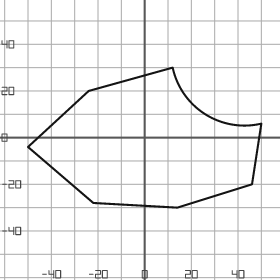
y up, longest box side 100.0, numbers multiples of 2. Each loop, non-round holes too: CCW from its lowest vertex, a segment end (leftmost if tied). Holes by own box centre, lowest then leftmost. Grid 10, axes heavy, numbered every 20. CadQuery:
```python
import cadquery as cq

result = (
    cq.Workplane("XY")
    .moveTo(14.0, -30.0)
    .lineTo(46.0, -20.0)
    .lineTo(50.0, 6.0)
    .threePointArc((26.0, 10.0), (12.0, 30.0))
    .lineTo(-24.0, 20.0)
    .lineTo(-50.0, -4.0)
    .lineTo(-22.0, -28.0)
    .close()
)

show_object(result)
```